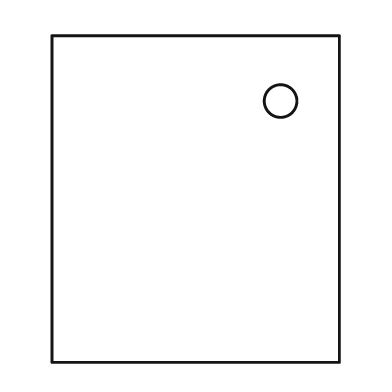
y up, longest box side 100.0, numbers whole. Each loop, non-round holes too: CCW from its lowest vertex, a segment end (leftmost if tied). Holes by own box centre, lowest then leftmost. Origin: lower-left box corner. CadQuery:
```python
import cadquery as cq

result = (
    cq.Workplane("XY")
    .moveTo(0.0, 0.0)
    .lineTo(88.0, 0.0)
    .lineTo(88.0, 100.0)
    .lineTo(0.0, 100.0)
    .close()
    .moveTo(70.0, 80.0)
    .circle(5.0)
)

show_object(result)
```